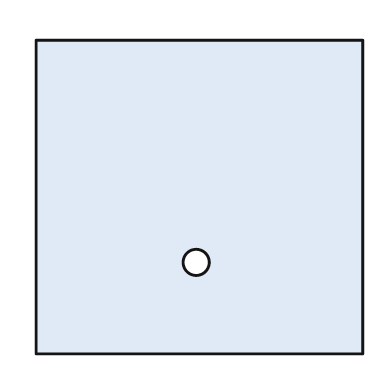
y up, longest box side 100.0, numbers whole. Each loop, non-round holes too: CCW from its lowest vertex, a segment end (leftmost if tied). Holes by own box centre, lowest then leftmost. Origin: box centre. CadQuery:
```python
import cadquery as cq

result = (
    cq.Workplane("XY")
    .moveTo(-50.0, -48.0)
    .lineTo(50.0, -48.0)
    .lineTo(50.0, 48.0)
    .lineTo(-50.0, 48.0)
    .close()
    .moveTo(-1.0, -20.0)
    .circle(4.0)
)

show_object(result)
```